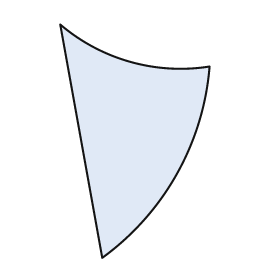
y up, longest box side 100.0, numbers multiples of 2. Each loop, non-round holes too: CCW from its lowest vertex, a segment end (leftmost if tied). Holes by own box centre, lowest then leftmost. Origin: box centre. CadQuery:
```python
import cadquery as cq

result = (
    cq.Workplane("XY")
    .moveTo(-14.0, -50.0)
    .threePointArc((18.0, -14.0), (32.0, 32.0))
    .threePointArc((-2.0, 34.0), (-32.0, 50.0))
    .close()
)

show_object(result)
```